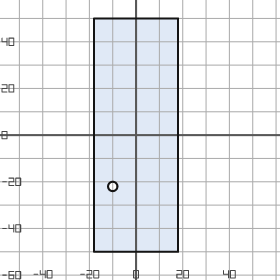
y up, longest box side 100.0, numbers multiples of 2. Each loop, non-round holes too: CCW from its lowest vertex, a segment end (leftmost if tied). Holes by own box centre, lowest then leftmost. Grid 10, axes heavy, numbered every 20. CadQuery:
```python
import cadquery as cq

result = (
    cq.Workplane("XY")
    .moveTo(-18.0, -50.0)
    .lineTo(18.0, -50.0)
    .lineTo(18.0, 50.0)
    .lineTo(-18.0, 50.0)
    .close()
    .moveTo(-10.0, -22.0)
    .circle(2.0)
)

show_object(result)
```